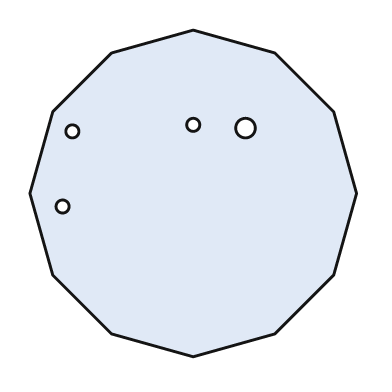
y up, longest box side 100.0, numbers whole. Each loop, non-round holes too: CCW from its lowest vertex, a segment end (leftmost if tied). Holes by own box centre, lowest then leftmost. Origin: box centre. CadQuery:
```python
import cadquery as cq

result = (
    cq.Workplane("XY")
    .moveTo(0.0, -50.0)
    .lineTo(25.0, -43.0)
    .lineTo(43.0, -25.0)
    .lineTo(50.0, 0.0)
    .lineTo(43.0, 25.0)
    .lineTo(25.0, 43.0)
    .lineTo(0.0, 50.0)
    .lineTo(-25.0, 43.0)
    .lineTo(-43.0, 25.0)
    .lineTo(-50.0, 0.0)
    .lineTo(-43.0, -25.0)
    .lineTo(-25.0, -43.0)
    .close()
    .moveTo(-40.0, -4.0)
    .circle(2.0)
    .moveTo(-37.0, 19.0)
    .circle(2.0)
    .moveTo(16.0, 20.0)
    .circle(3.0)
    .moveTo(0.0, 21.0)
    .circle(2.0)
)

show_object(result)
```